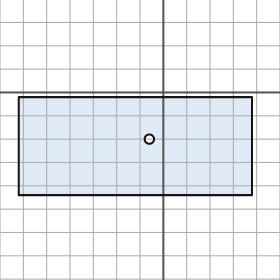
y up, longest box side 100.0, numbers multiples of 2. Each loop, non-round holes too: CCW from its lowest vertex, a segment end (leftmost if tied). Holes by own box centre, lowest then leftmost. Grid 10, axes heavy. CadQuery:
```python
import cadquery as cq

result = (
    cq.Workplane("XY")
    .moveTo(-62.0, -44.0)
    .lineTo(38.0, -44.0)
    .lineTo(38.0, -2.0)
    .lineTo(-62.0, -2.0)
    .close()
    .moveTo(-6.0, -20.0)
    .circle(2.0)
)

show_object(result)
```